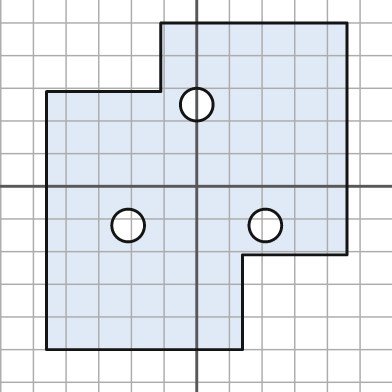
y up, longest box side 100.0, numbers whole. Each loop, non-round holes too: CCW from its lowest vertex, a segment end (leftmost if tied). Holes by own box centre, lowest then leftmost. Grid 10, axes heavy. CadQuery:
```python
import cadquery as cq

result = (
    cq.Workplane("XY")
    .moveTo(-46.0, -50.0)
    .lineTo(14.0, -50.0)
    .lineTo(14.0, -21.0)
    .lineTo(46.0, -21.0)
    .lineTo(46.0, 50.0)
    .lineTo(-11.0, 50.0)
    .lineTo(-11.0, 29.0)
    .lineTo(-46.0, 29.0)
    .close()
    .moveTo(-21.0, -12.0)
    .circle(5.0)
    .moveTo(21.0, -12.0)
    .circle(5.0)
    .moveTo(0.0, 25.0)
    .circle(5.0)
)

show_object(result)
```